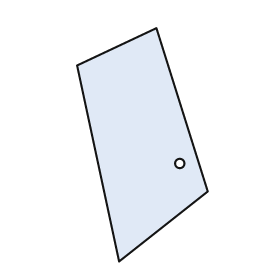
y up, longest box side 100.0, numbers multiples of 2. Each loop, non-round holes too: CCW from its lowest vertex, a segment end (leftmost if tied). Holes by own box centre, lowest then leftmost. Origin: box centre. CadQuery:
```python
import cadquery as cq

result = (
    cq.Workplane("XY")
    .moveTo(-10.0, -50.0)
    .lineTo(28.0, -20.0)
    .lineTo(6.0, 50.0)
    .lineTo(-28.0, 34.0)
    .close()
    .moveTo(16.0, -8.0)
    .circle(2.0)
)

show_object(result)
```